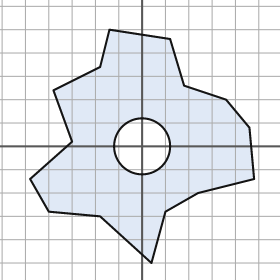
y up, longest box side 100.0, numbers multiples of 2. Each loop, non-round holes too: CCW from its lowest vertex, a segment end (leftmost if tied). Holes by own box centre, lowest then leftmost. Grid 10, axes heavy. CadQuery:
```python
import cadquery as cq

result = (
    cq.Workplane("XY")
    .moveTo(4.0, -50.0)
    .lineTo(10.0, -28.0)
    .lineTo(24.0, -20.0)
    .lineTo(48.0, -14.0)
    .lineTo(46.0, 8.0)
    .lineTo(36.0, 20.0)
    .lineTo(18.0, 26.0)
    .lineTo(12.0, 46.0)
    .lineTo(-14.0, 50.0)
    .lineTo(-18.0, 34.0)
    .lineTo(-38.0, 24.0)
    .lineTo(-30.0, 2.0)
    .lineTo(-48.0, -14.0)
    .lineTo(-40.0, -28.0)
    .lineTo(-18.0, -30.0)
    .close()
    .moveTo(0.0, 0.0)
    .circle(12.0)
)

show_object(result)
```